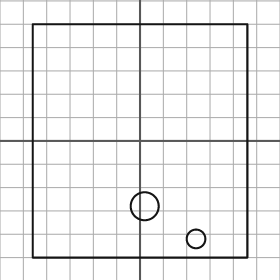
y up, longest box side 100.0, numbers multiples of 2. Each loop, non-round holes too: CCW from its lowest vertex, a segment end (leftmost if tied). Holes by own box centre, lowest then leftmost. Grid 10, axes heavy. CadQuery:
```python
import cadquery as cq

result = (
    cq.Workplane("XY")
    .moveTo(-46.0, -50.0)
    .lineTo(46.0, -50.0)
    .lineTo(46.0, 50.0)
    .lineTo(-46.0, 50.0)
    .close()
    .moveTo(24.0, -42.0)
    .circle(4.0)
    .moveTo(2.0, -28.0)
    .circle(6.0)
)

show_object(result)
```